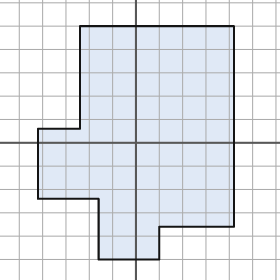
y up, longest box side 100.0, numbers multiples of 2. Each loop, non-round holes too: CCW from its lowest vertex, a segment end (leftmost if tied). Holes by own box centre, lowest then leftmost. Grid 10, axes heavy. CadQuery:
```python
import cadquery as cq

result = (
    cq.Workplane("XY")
    .moveTo(-16.0, -50.0)
    .lineTo(10.0, -50.0)
    .lineTo(10.0, -36.0)
    .lineTo(42.0, -36.0)
    .lineTo(42.0, 50.0)
    .lineTo(-24.0, 50.0)
    .lineTo(-24.0, 6.0)
    .lineTo(-42.0, 6.0)
    .lineTo(-42.0, -24.0)
    .lineTo(-16.0, -24.0)
    .close()
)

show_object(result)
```